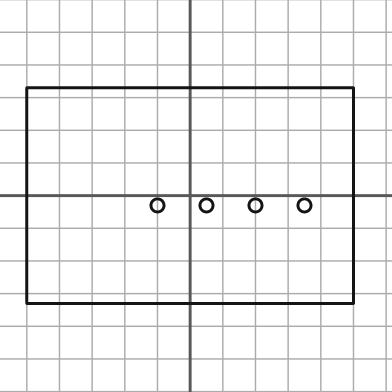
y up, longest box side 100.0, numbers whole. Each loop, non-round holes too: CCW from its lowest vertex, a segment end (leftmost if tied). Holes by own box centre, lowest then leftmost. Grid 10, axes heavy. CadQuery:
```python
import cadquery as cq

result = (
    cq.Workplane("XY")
    .moveTo(-50.0, -33.0)
    .lineTo(50.0, -33.0)
    .lineTo(50.0, 33.0)
    .lineTo(-50.0, 33.0)
    .close()
    .moveTo(-10.0, -3.0)
    .circle(2.0)
    .moveTo(5.0, -3.0)
    .circle(2.0)
    .moveTo(20.0, -3.0)
    .circle(2.0)
    .moveTo(35.0, -3.0)
    .circle(2.0)
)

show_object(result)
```